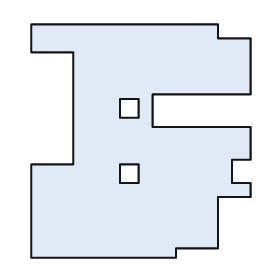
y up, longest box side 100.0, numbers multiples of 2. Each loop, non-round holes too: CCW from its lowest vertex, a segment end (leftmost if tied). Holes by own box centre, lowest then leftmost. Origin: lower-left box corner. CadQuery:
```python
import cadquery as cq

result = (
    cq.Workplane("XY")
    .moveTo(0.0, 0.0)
    .lineTo(62.0, 0.0)
    .lineTo(62.0, 4.0)
    .lineTo(80.0, 4.0)
    .lineTo(80.0, 26.0)
    .lineTo(94.0, 26.0)
    .lineTo(94.0, 32.0)
    .lineTo(86.0, 32.0)
    .lineTo(86.0, 42.0)
    .lineTo(94.0, 42.0)
    .lineTo(94.0, 56.0)
    .lineTo(52.0, 56.0)
    .lineTo(52.0, 70.0)
    .lineTo(94.0, 70.0)
    .lineTo(94.0, 94.0)
    .lineTo(80.0, 94.0)
    .lineTo(80.0, 100.0)
    .lineTo(0.0, 100.0)
    .lineTo(0.0, 88.0)
    .lineTo(18.0, 88.0)
    .lineTo(18.0, 40.0)
    .lineTo(0.0, 40.0)
    .close()
    .moveTo(38.0, 32.0)
    .lineTo(46.0, 32.0)
    .lineTo(46.0, 40.0)
    .lineTo(38.0, 40.0)
    .close()
    .moveTo(38.0, 60.0)
    .lineTo(46.0, 60.0)
    .lineTo(46.0, 68.0)
    .lineTo(38.0, 68.0)
    .close()
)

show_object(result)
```